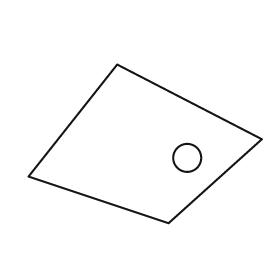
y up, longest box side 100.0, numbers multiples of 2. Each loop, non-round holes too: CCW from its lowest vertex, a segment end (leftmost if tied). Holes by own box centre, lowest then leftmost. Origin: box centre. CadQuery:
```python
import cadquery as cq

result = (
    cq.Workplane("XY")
    .moveTo(10.0, -34.0)
    .lineTo(50.0, 2.0)
    .lineTo(-12.0, 34.0)
    .lineTo(-50.0, -14.0)
    .close()
    .moveTo(18.0, -6.0)
    .circle(6.0)
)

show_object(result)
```